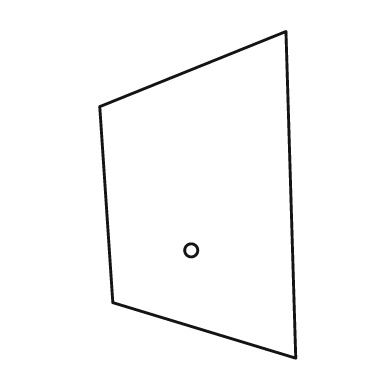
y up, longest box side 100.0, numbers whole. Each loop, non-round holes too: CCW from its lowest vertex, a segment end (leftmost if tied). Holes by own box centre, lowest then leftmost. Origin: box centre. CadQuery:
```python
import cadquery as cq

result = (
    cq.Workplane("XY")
    .moveTo(30.0, -50.0)
    .lineTo(27.0, 50.0)
    .lineTo(-30.0, 27.0)
    .lineTo(-26.0, -33.0)
    .close()
    .moveTo(-2.0, -17.0)
    .circle(2.0)
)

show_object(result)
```